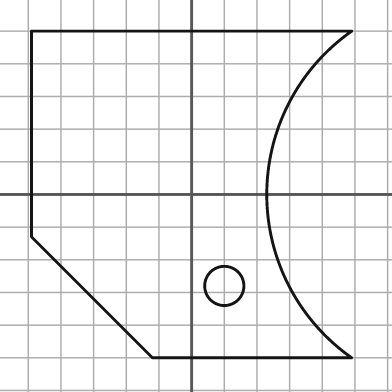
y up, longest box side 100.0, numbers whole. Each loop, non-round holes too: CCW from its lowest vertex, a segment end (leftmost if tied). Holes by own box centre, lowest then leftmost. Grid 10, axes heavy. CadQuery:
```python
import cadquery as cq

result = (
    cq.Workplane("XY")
    .moveTo(-12.0, -50.0)
    .lineTo(49.0, -50.0)
    .threePointArc((23.0, 0.0), (49.0, 50.0))
    .lineTo(-49.0, 50.0)
    .lineTo(-49.0, -13.0)
    .close()
    .moveTo(10.0, -28.0)
    .circle(6.0)
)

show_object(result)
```